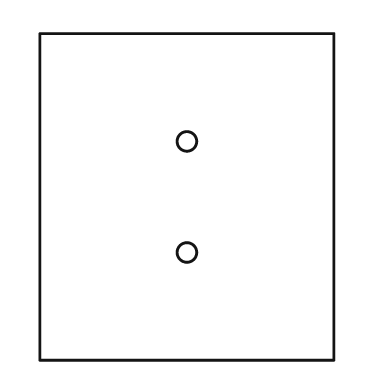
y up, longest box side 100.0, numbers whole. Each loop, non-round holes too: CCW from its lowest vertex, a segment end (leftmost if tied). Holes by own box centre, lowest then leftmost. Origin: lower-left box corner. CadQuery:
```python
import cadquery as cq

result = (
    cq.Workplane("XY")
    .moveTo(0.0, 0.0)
    .lineTo(90.0, 0.0)
    .lineTo(90.0, 100.0)
    .lineTo(0.0, 100.0)
    .close()
    .moveTo(45.0, 33.0)
    .circle(3.0)
    .moveTo(45.0, 67.0)
    .circle(3.0)
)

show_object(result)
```